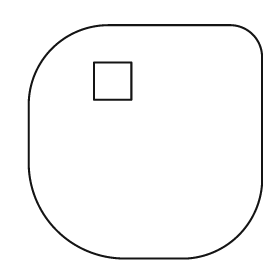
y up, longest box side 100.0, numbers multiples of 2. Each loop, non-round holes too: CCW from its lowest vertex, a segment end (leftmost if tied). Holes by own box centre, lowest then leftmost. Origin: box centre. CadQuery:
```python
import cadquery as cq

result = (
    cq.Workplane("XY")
    .moveTo(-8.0, -50.0)
    .lineTo(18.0, -50.0)
    .threePointArc((40.0, -40.0), (50.0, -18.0))
    .lineTo(50.0, 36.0)
    .threePointArc((46.0, 46.0), (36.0, 50.0))
    .lineTo(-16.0, 50.0)
    .threePointArc((-40.0, 40.0), (-50.0, 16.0))
    .lineTo(-50.0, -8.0)
    .threePointArc((-38.0, -38.0), (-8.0, -50.0))
    .close()
    .moveTo(-22.0, 18.0)
    .lineTo(-6.0, 18.0)
    .lineTo(-6.0, 34.0)
    .lineTo(-22.0, 34.0)
    .close()
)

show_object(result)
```